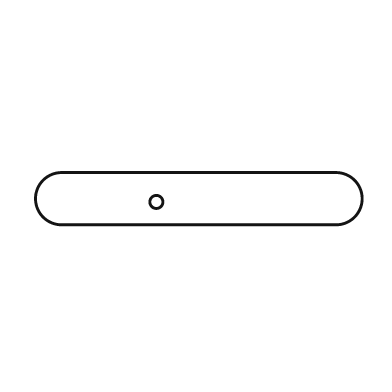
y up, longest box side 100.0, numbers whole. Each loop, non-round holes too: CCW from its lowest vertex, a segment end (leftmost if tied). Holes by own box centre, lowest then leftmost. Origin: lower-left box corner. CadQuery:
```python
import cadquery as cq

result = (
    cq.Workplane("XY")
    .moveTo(8.0, 0.0)
    .lineTo(92.0, 0.0)
    .threePointArc((100.0, 8.0), (92.0, 16.0))
    .lineTo(8.0, 16.0)
    .threePointArc((0.0, 8.0), (8.0, 0.0))
    .close()
    .moveTo(37.0, 7.0)
    .circle(2.0)
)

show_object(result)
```